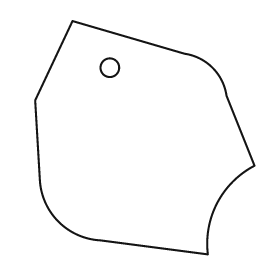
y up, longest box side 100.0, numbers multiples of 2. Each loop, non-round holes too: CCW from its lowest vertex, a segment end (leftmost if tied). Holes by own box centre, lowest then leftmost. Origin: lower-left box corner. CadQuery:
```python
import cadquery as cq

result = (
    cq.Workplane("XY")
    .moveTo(74.0, 0.0)
    .threePointArc((78.0, 22.0), (94.0, 38.0))
    .lineTo(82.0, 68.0)
    .threePointArc((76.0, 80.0), (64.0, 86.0))
    .lineTo(16.0, 100.0)
    .lineTo(0.0, 66.0)
    .lineTo(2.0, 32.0)
    .threePointArc((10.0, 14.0), (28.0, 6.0))
    .close()
    .moveTo(32.0, 80.0)
    .circle(4.0)
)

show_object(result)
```